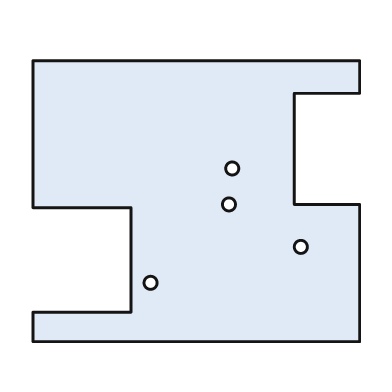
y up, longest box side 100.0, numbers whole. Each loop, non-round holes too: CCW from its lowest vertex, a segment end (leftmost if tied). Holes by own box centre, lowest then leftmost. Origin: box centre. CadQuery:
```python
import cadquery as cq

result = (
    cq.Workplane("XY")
    .moveTo(-50.0, -43.0)
    .lineTo(50.0, -43.0)
    .lineTo(50.0, -1.0)
    .lineTo(30.0, -1.0)
    .lineTo(30.0, 33.0)
    .lineTo(50.0, 33.0)
    .lineTo(50.0, 43.0)
    .lineTo(-50.0, 43.0)
    .lineTo(-50.0, -2.0)
    .lineTo(-20.0, -2.0)
    .lineTo(-20.0, -34.0)
    .lineTo(-50.0, -34.0)
    .close()
    .moveTo(-14.0, -25.0)
    .circle(2.0)
    .moveTo(32.0, -14.0)
    .circle(2.0)
    .moveTo(10.0, -1.0)
    .circle(2.0)
    .moveTo(11.0, 10.0)
    .circle(2.0)
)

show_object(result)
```